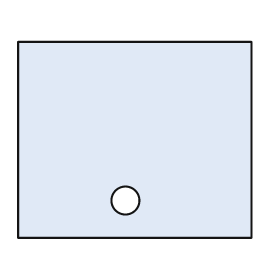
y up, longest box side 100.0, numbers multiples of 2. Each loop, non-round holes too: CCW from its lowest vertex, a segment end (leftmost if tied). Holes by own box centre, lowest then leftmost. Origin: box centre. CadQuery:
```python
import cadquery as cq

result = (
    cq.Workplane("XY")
    .moveTo(-50.0, -42.0)
    .lineTo(50.0, -42.0)
    .lineTo(50.0, 42.0)
    .lineTo(-50.0, 42.0)
    .close()
    .moveTo(-4.0, -26.0)
    .circle(6.0)
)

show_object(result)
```